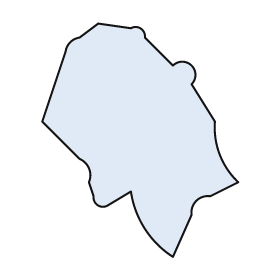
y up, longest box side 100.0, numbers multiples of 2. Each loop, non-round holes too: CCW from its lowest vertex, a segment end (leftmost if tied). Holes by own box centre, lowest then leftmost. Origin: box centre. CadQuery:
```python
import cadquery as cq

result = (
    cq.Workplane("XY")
    .moveTo(14.0, -50.0)
    .lineTo(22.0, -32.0)
    .threePointArc((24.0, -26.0), (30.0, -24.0))
    .lineTo(42.0, -18.0)
    .threePointArc((34.0, -6.0), (32.0, 8.0))
    .lineTo(22.0, 24.0)
    .threePointArc((22.0, 32.0), (14.0, 32.0))
    .lineTo(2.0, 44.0)
    .threePointArc((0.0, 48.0), (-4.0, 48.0))
    .lineTo(-18.0, 50.0)
    .lineTo(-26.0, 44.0)
    .threePointArc((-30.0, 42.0), (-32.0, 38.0))
    .lineTo(-42.0, 8.0)
    .lineTo(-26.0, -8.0)
    .threePointArc((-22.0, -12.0), (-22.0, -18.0))
    .lineTo(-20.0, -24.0)
    .threePointArc((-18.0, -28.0), (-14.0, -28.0))
    .lineTo(-4.0, -22.0)
    .threePointArc((2.0, -38.0), (14.0, -50.0))
    .close()
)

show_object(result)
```